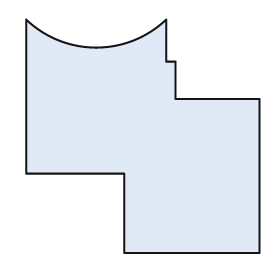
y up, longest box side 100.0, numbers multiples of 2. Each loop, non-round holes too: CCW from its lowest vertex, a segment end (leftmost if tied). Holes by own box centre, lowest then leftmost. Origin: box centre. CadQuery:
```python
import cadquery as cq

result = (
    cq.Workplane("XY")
    .moveTo(-8.0, -50.0)
    .lineTo(50.0, -50.0)
    .lineTo(50.0, 16.0)
    .lineTo(14.0, 16.0)
    .lineTo(14.0, 32.0)
    .lineTo(10.0, 32.0)
    .lineTo(10.0, 50.0)
    .threePointArc((-20.0, 38.0), (-50.0, 50.0))
    .lineTo(-50.0, -16.0)
    .lineTo(-8.0, -16.0)
    .close()
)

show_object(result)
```